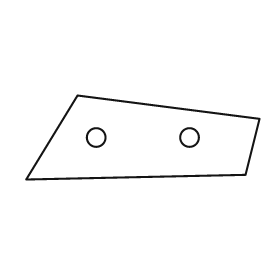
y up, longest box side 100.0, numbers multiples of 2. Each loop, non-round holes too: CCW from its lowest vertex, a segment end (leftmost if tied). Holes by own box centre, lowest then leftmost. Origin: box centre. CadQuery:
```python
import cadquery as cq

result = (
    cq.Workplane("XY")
    .moveTo(-50.0, -18.0)
    .lineTo(44.0, -16.0)
    .lineTo(50.0, 8.0)
    .lineTo(-28.0, 18.0)
    .close()
    .moveTo(-20.0, 0.0)
    .circle(4.0)
    .moveTo(20.0, 0.0)
    .circle(4.0)
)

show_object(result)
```